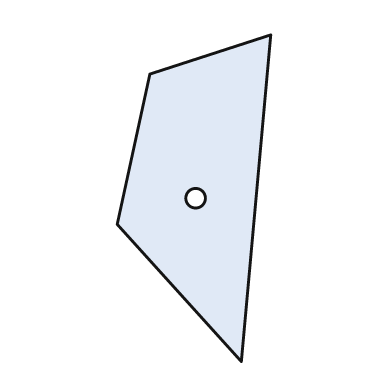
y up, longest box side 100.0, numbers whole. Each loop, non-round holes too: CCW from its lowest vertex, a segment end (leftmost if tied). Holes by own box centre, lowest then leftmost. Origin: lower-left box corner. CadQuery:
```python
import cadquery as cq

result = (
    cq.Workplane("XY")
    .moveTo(38.0, 0.0)
    .lineTo(47.0, 100.0)
    .lineTo(10.0, 88.0)
    .lineTo(0.0, 42.0)
    .close()
    .moveTo(24.0, 50.0)
    .circle(3.0)
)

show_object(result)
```